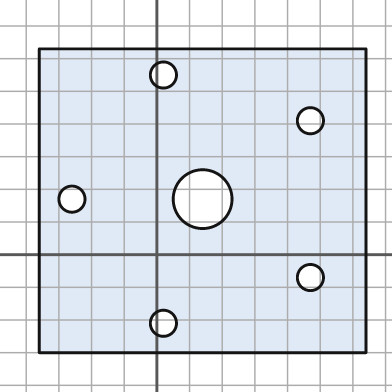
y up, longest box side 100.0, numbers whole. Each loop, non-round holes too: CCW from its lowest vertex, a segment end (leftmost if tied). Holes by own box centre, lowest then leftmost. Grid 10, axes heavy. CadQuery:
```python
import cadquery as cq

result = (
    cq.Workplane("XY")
    .moveTo(-36.0, -30.0)
    .lineTo(64.0, -30.0)
    .lineTo(64.0, 63.0)
    .lineTo(-36.0, 63.0)
    .close()
    .moveTo(2.0, -21.0)
    .circle(4.0)
    .moveTo(47.0, -7.0)
    .circle(4.0)
    .moveTo(-26.0, 17.0)
    .circle(4.0)
    .moveTo(14.0, 17.0)
    .circle(9.0)
    .moveTo(47.0, 41.0)
    .circle(4.0)
    .moveTo(2.0, 55.0)
    .circle(4.0)
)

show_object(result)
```